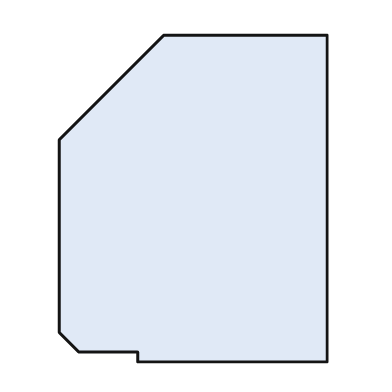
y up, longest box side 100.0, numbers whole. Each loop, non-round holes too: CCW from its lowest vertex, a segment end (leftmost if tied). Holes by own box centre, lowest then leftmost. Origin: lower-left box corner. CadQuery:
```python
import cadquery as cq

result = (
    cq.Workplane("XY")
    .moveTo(24.0, 0.0)
    .lineTo(82.0, 0.0)
    .lineTo(82.0, 100.0)
    .lineTo(32.0, 100.0)
    .lineTo(0.0, 68.0)
    .lineTo(0.0, 9.0)
    .lineTo(6.0, 3.0)
    .lineTo(24.0, 3.0)
    .close()
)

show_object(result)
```